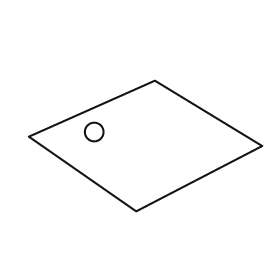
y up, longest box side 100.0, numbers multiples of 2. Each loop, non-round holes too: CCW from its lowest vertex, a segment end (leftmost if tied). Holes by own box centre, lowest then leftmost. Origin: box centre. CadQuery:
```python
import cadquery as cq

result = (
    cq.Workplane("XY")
    .moveTo(-4.0, -28.0)
    .lineTo(50.0, 0.0)
    .lineTo(4.0, 28.0)
    .lineTo(-50.0, 4.0)
    .close()
    .moveTo(-22.0, 6.0)
    .circle(4.0)
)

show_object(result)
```